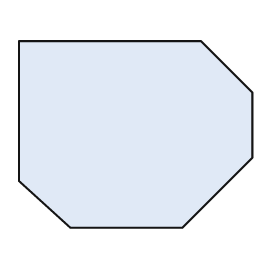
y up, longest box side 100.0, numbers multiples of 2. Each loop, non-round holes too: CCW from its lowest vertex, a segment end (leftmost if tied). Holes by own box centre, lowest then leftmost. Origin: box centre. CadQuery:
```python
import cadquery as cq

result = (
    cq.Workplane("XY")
    .moveTo(-28.0, -40.0)
    .lineTo(20.0, -40.0)
    .lineTo(50.0, -10.0)
    .lineTo(50.0, 18.0)
    .lineTo(28.0, 40.0)
    .lineTo(-50.0, 40.0)
    .lineTo(-50.0, -20.0)
    .close()
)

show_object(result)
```